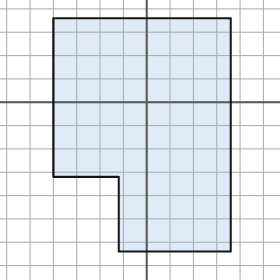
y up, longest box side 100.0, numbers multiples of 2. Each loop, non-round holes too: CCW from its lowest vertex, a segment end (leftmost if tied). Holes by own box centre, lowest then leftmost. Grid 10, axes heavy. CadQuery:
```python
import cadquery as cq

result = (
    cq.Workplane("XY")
    .moveTo(-12.0, -64.0)
    .lineTo(36.0, -64.0)
    .lineTo(36.0, 36.0)
    .lineTo(-40.0, 36.0)
    .lineTo(-40.0, -32.0)
    .lineTo(-12.0, -32.0)
    .close()
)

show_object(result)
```